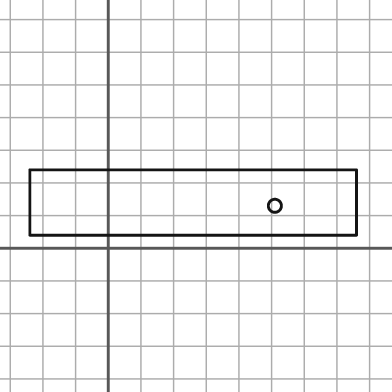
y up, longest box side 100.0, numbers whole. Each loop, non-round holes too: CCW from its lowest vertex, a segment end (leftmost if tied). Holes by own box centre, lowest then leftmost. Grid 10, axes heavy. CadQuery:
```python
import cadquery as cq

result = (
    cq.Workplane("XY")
    .moveTo(-24.0, 4.0)
    .lineTo(76.0, 4.0)
    .lineTo(76.0, 24.0)
    .lineTo(-24.0, 24.0)
    .close()
    .moveTo(51.0, 13.0)
    .circle(2.0)
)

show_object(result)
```